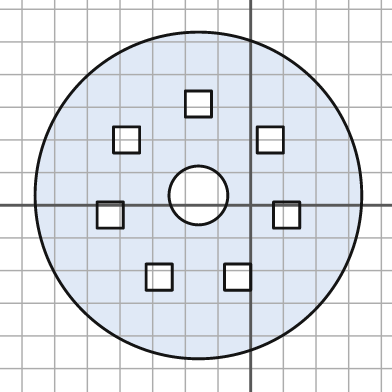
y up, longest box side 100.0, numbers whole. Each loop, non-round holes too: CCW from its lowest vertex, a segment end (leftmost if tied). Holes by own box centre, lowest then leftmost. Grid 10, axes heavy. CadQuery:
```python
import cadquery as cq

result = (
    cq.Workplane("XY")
    .moveTo(-16.0, 3.0)
    .circle(50.0)
    .moveTo(-32.0, -26.0)
    .lineTo(-24.0, -26.0)
    .lineTo(-24.0, -18.0)
    .lineTo(-32.0, -18.0)
    .close()
    .moveTo(-8.0, -26.0)
    .lineTo(0.0, -26.0)
    .lineTo(0.0, -18.0)
    .lineTo(-8.0, -18.0)
    .close()
    .moveTo(-47.0, -7.0)
    .lineTo(-39.0, -7.0)
    .lineTo(-39.0, 1.0)
    .lineTo(-47.0, 1.0)
    .close()
    .moveTo(7.0, -7.0)
    .lineTo(15.0, -7.0)
    .lineTo(15.0, 1.0)
    .lineTo(7.0, 1.0)
    .close()
    .moveTo(-16.0, 3.0)
    .circle(9.0)
    .moveTo(-42.0, 16.0)
    .lineTo(-34.0, 16.0)
    .lineTo(-34.0, 24.0)
    .lineTo(-42.0, 24.0)
    .close()
    .moveTo(2.0, 16.0)
    .lineTo(10.0, 16.0)
    .lineTo(10.0, 24.0)
    .lineTo(2.0, 24.0)
    .close()
    .moveTo(-20.0, 27.0)
    .lineTo(-12.0, 27.0)
    .lineTo(-12.0, 35.0)
    .lineTo(-20.0, 35.0)
    .close()
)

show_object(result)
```